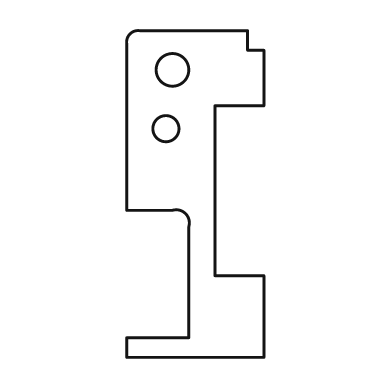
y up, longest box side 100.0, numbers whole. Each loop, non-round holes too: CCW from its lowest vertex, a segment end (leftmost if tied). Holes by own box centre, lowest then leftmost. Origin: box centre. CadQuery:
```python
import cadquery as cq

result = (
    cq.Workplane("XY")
    .moveTo(-21.0, -50.0)
    .lineTo(21.0, -50.0)
    .lineTo(21.0, -25.0)
    .lineTo(6.0, -25.0)
    .lineTo(6.0, 27.0)
    .lineTo(21.0, 27.0)
    .lineTo(21.0, 44.0)
    .lineTo(16.0, 44.0)
    .lineTo(16.0, 50.0)
    .lineTo(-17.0, 50.0)
    .threePointArc((-20.0, 49.0), (-21.0, 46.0))
    .lineTo(-21.0, -5.0)
    .lineTo(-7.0, -5.0)
    .threePointArc((-3.0, -6.0), (-2.0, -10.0))
    .lineTo(-2.0, -44.0)
    .lineTo(-21.0, -44.0)
    .close()
    .moveTo(-9.0, 20.0)
    .circle(4.0)
    .moveTo(-7.0, 38.0)
    .circle(5.0)
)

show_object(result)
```